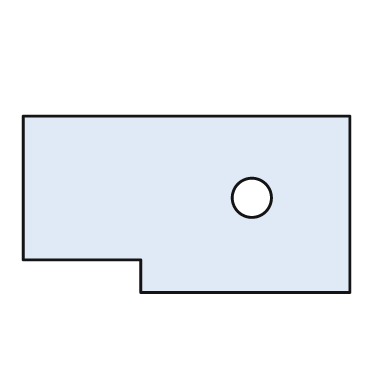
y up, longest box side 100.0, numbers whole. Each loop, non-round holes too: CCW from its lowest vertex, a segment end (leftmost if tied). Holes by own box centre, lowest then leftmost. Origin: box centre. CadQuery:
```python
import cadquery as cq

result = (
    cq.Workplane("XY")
    .moveTo(-14.0, -27.0)
    .lineTo(50.0, -27.0)
    .lineTo(50.0, 27.0)
    .lineTo(-50.0, 27.0)
    .lineTo(-50.0, -17.0)
    .lineTo(-14.0, -17.0)
    .close()
    .moveTo(20.0, 2.0)
    .circle(6.0)
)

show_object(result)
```